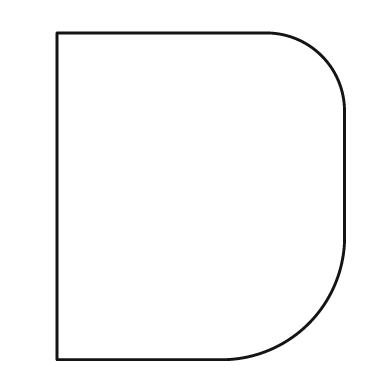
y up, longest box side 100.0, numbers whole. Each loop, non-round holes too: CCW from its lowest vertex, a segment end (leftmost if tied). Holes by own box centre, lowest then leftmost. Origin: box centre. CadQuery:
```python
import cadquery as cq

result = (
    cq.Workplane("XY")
    .moveTo(-44.0, -50.0)
    .lineTo(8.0, -50.0)
    .threePointArc((33.0, -39.0), (44.0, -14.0))
    .lineTo(44.0, 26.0)
    .threePointArc((37.0, 43.0), (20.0, 50.0))
    .lineTo(-44.0, 50.0)
    .close()
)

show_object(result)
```